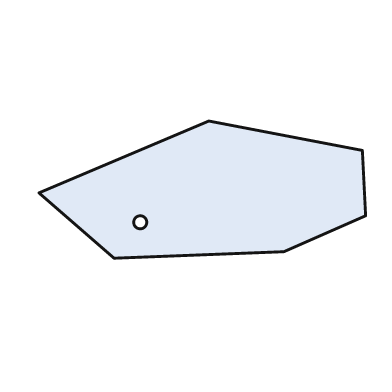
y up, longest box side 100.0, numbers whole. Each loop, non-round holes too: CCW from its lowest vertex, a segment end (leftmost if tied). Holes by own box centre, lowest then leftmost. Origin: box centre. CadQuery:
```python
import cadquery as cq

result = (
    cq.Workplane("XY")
    .moveTo(-27.0, -21.0)
    .lineTo(25.0, -19.0)
    .lineTo(50.0, -8.0)
    .lineTo(49.0, 12.0)
    .lineTo(2.0, 21.0)
    .lineTo(-50.0, -1.0)
    .close()
    .moveTo(-19.0, -10.0)
    .circle(2.0)
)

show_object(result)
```